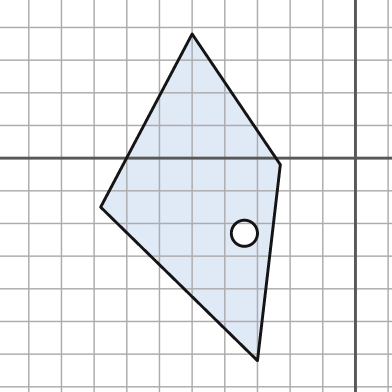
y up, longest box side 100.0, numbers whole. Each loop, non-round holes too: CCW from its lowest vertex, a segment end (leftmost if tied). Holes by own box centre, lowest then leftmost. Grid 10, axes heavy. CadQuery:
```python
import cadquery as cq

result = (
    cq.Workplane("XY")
    .moveTo(-30.0, -62.0)
    .lineTo(-23.0, -2.0)
    .lineTo(-50.0, 38.0)
    .lineTo(-78.0, -15.0)
    .close()
    .moveTo(-34.0, -23.0)
    .circle(4.0)
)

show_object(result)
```